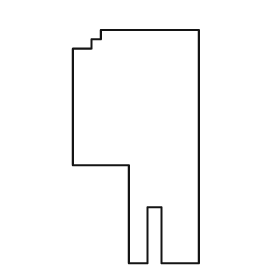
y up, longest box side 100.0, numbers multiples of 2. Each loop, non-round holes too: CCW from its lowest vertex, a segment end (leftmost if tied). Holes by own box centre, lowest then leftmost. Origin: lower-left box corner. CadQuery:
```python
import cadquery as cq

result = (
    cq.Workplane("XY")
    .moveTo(24.0, 0.0)
    .lineTo(32.0, 0.0)
    .lineTo(32.0, 24.0)
    .lineTo(38.0, 24.0)
    .lineTo(38.0, 0.0)
    .lineTo(54.0, 0.0)
    .lineTo(54.0, 100.0)
    .lineTo(12.0, 100.0)
    .lineTo(12.0, 96.0)
    .lineTo(8.0, 96.0)
    .lineTo(8.0, 92.0)
    .lineTo(0.0, 92.0)
    .lineTo(0.0, 42.0)
    .lineTo(24.0, 42.0)
    .close()
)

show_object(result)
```